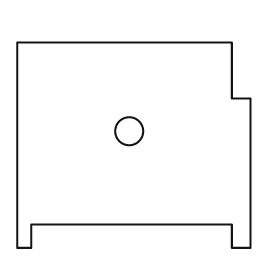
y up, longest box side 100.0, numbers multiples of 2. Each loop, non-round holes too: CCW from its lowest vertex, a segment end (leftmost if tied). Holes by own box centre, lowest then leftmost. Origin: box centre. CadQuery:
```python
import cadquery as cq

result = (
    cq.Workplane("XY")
    .moveTo(-50.0, -44.0)
    .lineTo(-44.0, -44.0)
    .lineTo(-44.0, -34.0)
    .lineTo(42.0, -34.0)
    .lineTo(42.0, -44.0)
    .lineTo(50.0, -44.0)
    .lineTo(50.0, 20.0)
    .lineTo(42.0, 20.0)
    .lineTo(42.0, 44.0)
    .lineTo(-50.0, 44.0)
    .close()
    .moveTo(-2.0, 6.0)
    .circle(6.0)
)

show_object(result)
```